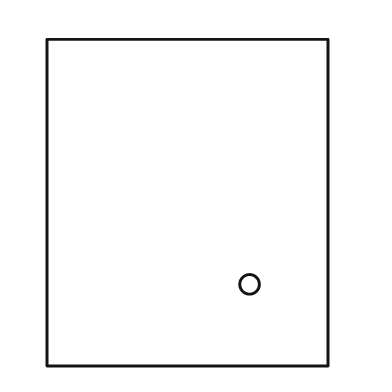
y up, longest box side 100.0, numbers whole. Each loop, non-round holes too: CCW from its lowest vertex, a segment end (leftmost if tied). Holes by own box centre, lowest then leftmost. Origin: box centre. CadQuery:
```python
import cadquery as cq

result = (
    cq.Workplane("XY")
    .moveTo(-43.0, -50.0)
    .lineTo(43.0, -50.0)
    .lineTo(43.0, 50.0)
    .lineTo(-43.0, 50.0)
    .close()
    .moveTo(19.0, -25.0)
    .circle(3.0)
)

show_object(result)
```